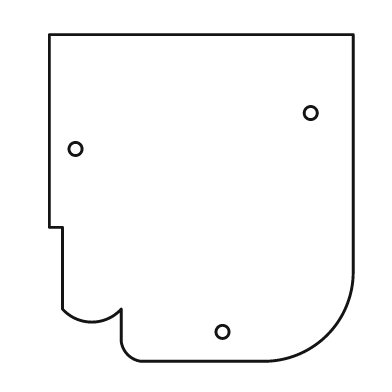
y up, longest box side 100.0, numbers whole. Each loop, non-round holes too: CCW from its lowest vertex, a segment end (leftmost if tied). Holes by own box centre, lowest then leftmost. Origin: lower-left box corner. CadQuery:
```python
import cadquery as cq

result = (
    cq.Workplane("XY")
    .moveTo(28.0, 0.0)
    .lineTo(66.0, 0.0)
    .threePointArc((85.0, 8.0), (93.0, 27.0))
    .lineTo(93.0, 100.0)
    .lineTo(0.0, 100.0)
    .lineTo(0.0, 41.0)
    .lineTo(4.0, 41.0)
    .lineTo(4.0, 16.0)
    .threePointArc((13.0, 12.0), (22.0, 16.0))
    .lineTo(22.0, 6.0)
    .threePointArc((24.0, 2.0), (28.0, 0.0))
    .close()
    .moveTo(53.0, 9.0)
    .circle(2.0)
    .moveTo(8.0, 65.0)
    .circle(2.0)
    .moveTo(80.0, 76.0)
    .circle(2.0)
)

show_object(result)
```